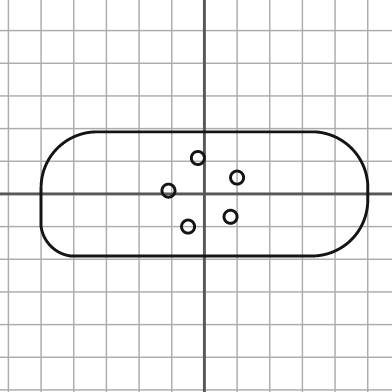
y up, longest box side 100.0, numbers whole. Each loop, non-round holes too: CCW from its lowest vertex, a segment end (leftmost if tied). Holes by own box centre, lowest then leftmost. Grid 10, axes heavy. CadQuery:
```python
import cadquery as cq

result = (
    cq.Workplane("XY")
    .moveTo(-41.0, -19.0)
    .lineTo(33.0, -19.0)
    .threePointArc((45.0, -14.0), (50.0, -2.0))
    .lineTo(50.0, 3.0)
    .threePointArc((45.0, 14.0), (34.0, 19.0))
    .lineTo(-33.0, 19.0)
    .threePointArc((-45.0, 14.0), (-50.0, 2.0))
    .lineTo(-50.0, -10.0)
    .threePointArc((-47.0, -16.0), (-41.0, -19.0))
    .close()
    .moveTo(-5.0, -10.0)
    .circle(2.0)
    .moveTo(8.0, -7.0)
    .circle(2.0)
    .moveTo(-11.0, 1.0)
    .circle(2.0)
    .moveTo(10.0, 5.0)
    .circle(2.0)
    .moveTo(-2.0, 11.0)
    .circle(2.0)
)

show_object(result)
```